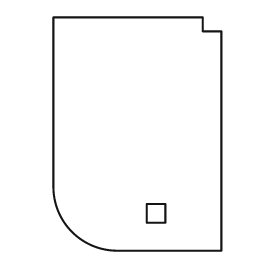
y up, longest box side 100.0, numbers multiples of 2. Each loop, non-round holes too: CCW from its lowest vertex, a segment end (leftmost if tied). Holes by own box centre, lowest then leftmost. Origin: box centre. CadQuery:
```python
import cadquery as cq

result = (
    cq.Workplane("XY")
    .moveTo(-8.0, -50.0)
    .lineTo(36.0, -50.0)
    .lineTo(36.0, 44.0)
    .lineTo(28.0, 44.0)
    .lineTo(28.0, 50.0)
    .lineTo(-36.0, 50.0)
    .lineTo(-36.0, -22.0)
    .threePointArc((-28.0, -42.0), (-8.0, -50.0))
    .close()
    .moveTo(4.0, -38.0)
    .lineTo(12.0, -38.0)
    .lineTo(12.0, -30.0)
    .lineTo(4.0, -30.0)
    .close()
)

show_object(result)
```